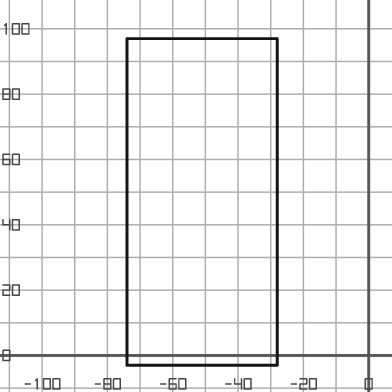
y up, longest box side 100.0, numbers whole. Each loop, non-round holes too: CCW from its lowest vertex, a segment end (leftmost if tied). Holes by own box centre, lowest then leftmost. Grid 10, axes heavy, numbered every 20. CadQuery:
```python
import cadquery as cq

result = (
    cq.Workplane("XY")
    .moveTo(-74.0, -3.0)
    .lineTo(-28.0, -3.0)
    .lineTo(-28.0, 97.0)
    .lineTo(-74.0, 97.0)
    .close()
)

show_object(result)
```